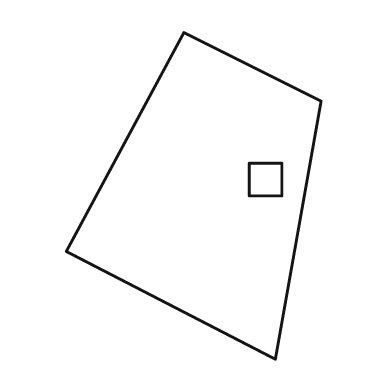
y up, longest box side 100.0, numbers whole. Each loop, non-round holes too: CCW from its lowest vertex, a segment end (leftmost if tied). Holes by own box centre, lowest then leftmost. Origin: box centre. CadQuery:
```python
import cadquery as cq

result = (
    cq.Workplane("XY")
    .moveTo(25.0, -50.0)
    .lineTo(39.0, 29.0)
    .lineTo(-3.0, 50.0)
    .lineTo(-39.0, -17.0)
    .close()
    .moveTo(17.0, 0.0)
    .lineTo(27.0, 0.0)
    .lineTo(27.0, 10.0)
    .lineTo(17.0, 10.0)
    .close()
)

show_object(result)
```